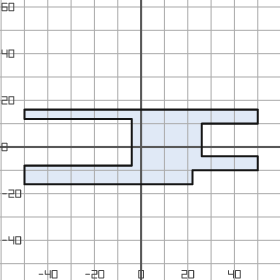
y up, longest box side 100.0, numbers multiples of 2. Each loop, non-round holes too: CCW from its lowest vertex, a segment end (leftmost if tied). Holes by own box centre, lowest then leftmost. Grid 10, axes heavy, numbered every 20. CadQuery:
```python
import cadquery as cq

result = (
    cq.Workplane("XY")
    .moveTo(-50.0, -16.0)
    .lineTo(22.0, -16.0)
    .lineTo(22.0, -10.0)
    .lineTo(50.0, -10.0)
    .lineTo(50.0, -4.0)
    .lineTo(26.0, -4.0)
    .lineTo(26.0, 10.0)
    .lineTo(50.0, 10.0)
    .lineTo(50.0, 16.0)
    .lineTo(-50.0, 16.0)
    .lineTo(-50.0, 12.0)
    .lineTo(-4.0, 12.0)
    .lineTo(-4.0, -8.0)
    .lineTo(-50.0, -8.0)
    .close()
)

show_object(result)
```